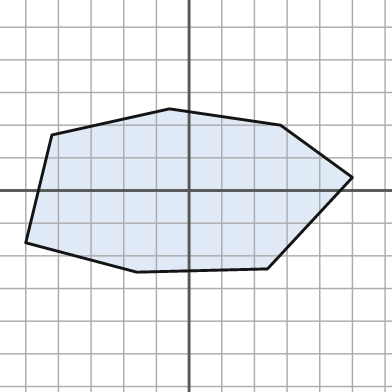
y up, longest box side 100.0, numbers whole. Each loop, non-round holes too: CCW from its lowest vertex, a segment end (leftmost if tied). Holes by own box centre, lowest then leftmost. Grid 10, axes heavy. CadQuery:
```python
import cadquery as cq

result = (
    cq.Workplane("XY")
    .moveTo(-16.0, -25.0)
    .lineTo(24.0, -24.0)
    .lineTo(50.0, 4.0)
    .lineTo(28.0, 20.0)
    .lineTo(-6.0, 25.0)
    .lineTo(-42.0, 17.0)
    .lineTo(-50.0, -16.0)
    .close()
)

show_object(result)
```